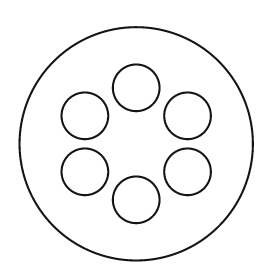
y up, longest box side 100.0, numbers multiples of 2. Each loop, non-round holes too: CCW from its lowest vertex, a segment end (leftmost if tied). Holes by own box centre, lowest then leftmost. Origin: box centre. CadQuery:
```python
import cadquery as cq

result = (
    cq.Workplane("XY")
    .moveTo(0.0, 0.0)
    .circle(50.0)
    .moveTo(0.0, -24.0)
    .circle(10.0)
    .moveTo(-22.0, -12.0)
    .circle(10.0)
    .moveTo(22.0, -12.0)
    .circle(10.0)
    .moveTo(-22.0, 12.0)
    .circle(10.0)
    .moveTo(22.0, 12.0)
    .circle(10.0)
    .moveTo(0.0, 24.0)
    .circle(10.0)
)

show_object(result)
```